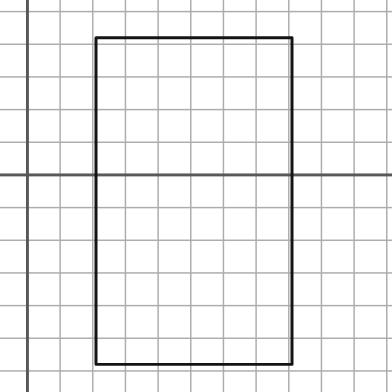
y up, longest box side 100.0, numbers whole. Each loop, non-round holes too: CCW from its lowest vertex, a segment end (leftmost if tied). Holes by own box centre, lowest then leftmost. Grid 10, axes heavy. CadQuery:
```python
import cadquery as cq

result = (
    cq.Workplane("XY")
    .moveTo(21.0, -58.0)
    .lineTo(81.0, -58.0)
    .lineTo(81.0, 42.0)
    .lineTo(21.0, 42.0)
    .close()
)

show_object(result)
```